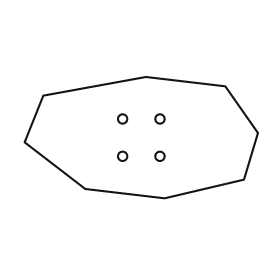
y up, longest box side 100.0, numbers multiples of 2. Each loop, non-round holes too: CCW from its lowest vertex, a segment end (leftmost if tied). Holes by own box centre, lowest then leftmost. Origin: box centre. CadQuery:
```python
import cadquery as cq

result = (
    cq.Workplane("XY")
    .moveTo(10.0, -26.0)
    .lineTo(44.0, -18.0)
    .lineTo(50.0, 2.0)
    .lineTo(36.0, 22.0)
    .lineTo(2.0, 26.0)
    .lineTo(-42.0, 18.0)
    .lineTo(-50.0, -2.0)
    .lineTo(-24.0, -22.0)
    .close()
    .moveTo(-8.0, -8.0)
    .circle(2.0)
    .moveTo(8.0, -8.0)
    .circle(2.0)
    .moveTo(-8.0, 8.0)
    .circle(2.0)
    .moveTo(8.0, 8.0)
    .circle(2.0)
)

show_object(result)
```